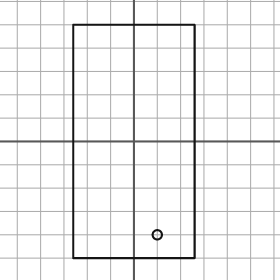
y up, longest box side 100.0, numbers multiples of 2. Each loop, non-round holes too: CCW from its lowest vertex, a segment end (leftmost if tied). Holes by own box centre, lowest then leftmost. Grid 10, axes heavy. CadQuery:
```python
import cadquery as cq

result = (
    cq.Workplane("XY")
    .moveTo(-26.0, -50.0)
    .lineTo(26.0, -50.0)
    .lineTo(26.0, 50.0)
    .lineTo(-26.0, 50.0)
    .close()
    .moveTo(10.0, -40.0)
    .circle(2.0)
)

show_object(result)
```